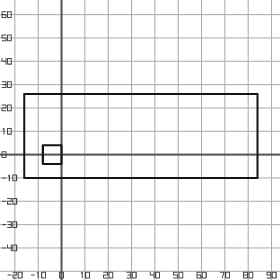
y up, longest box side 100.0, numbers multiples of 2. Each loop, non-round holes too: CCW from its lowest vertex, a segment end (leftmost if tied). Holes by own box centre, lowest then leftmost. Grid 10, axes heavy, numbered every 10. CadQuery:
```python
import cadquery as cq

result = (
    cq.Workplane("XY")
    .moveTo(-16.0, -10.0)
    .lineTo(84.0, -10.0)
    .lineTo(84.0, 26.0)
    .lineTo(-16.0, 26.0)
    .close()
    .moveTo(-8.0, -4.0)
    .lineTo(0.0, -4.0)
    .lineTo(0.0, 4.0)
    .lineTo(-8.0, 4.0)
    .close()
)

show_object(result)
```